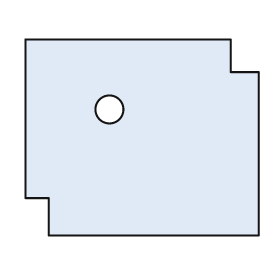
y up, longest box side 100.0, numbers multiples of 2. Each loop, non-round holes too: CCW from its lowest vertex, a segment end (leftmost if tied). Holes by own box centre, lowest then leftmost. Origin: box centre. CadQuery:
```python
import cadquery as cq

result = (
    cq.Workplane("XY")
    .moveTo(-40.0, -42.0)
    .lineTo(50.0, -42.0)
    .lineTo(50.0, 28.0)
    .lineTo(38.0, 28.0)
    .lineTo(38.0, 42.0)
    .lineTo(-50.0, 42.0)
    .lineTo(-50.0, -26.0)
    .lineTo(-40.0, -26.0)
    .close()
    .moveTo(-14.0, 12.0)
    .circle(6.0)
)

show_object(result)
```